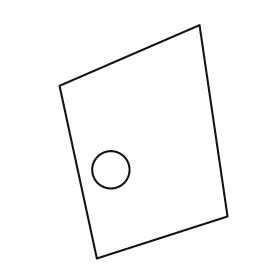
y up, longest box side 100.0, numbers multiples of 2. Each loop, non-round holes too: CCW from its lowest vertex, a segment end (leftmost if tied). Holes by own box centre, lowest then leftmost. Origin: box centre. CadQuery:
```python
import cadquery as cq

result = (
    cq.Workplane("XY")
    .moveTo(-20.0, -50.0)
    .lineTo(36.0, -32.0)
    .lineTo(24.0, 50.0)
    .lineTo(-36.0, 24.0)
    .close()
    .moveTo(-14.0, -12.0)
    .circle(8.0)
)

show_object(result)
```